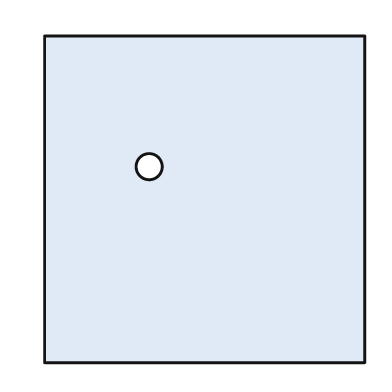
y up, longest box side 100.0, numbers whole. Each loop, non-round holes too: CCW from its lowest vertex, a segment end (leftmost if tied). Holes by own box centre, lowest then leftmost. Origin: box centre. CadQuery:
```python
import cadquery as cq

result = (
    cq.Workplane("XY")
    .moveTo(-49.0, -50.0)
    .lineTo(49.0, -50.0)
    .lineTo(49.0, 50.0)
    .lineTo(-49.0, 50.0)
    .close()
    .moveTo(-17.0, 10.0)
    .circle(4.0)
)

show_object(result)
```